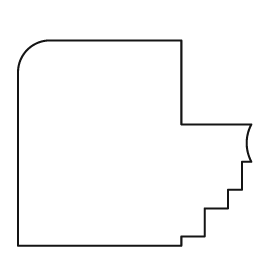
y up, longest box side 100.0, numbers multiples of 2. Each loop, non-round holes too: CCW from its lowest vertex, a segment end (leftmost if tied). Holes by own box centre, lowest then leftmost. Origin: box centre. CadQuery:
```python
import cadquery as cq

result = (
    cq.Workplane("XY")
    .moveTo(-50.0, -44.0)
    .lineTo(20.0, -44.0)
    .lineTo(20.0, -40.0)
    .lineTo(30.0, -40.0)
    .lineTo(30.0, -28.0)
    .lineTo(40.0, -28.0)
    .lineTo(40.0, -20.0)
    .lineTo(46.0, -20.0)
    .lineTo(46.0, -8.0)
    .lineTo(50.0, -8.0)
    .threePointArc((48.0, 0.0), (50.0, 8.0))
    .lineTo(20.0, 8.0)
    .lineTo(20.0, 44.0)
    .lineTo(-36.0, 44.0)
    .threePointArc((-46.0, 40.0), (-50.0, 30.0))
    .close()
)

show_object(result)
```